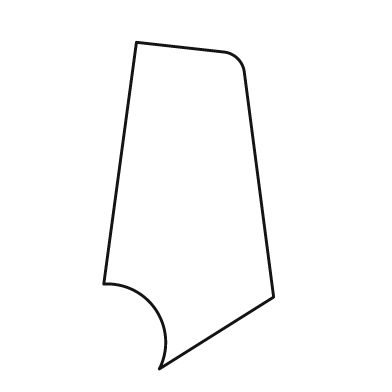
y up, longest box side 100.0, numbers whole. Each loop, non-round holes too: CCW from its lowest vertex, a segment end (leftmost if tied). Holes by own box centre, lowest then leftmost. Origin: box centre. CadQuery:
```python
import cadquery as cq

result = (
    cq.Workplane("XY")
    .moveTo(-9.0, -50.0)
    .lineTo(26.0, -28.0)
    .lineTo(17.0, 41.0)
    .threePointArc((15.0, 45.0), (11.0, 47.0))
    .lineTo(-16.0, 50.0)
    .lineTo(-26.0, -24.0)
    .threePointArc((-10.0, -32.0), (-9.0, -50.0))
    .close()
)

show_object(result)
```